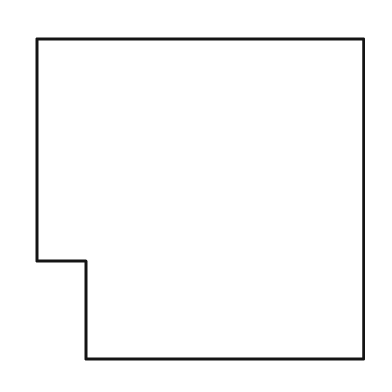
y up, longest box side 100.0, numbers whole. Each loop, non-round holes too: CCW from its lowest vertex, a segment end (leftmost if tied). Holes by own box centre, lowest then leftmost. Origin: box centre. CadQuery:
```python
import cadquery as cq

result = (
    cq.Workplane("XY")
    .moveTo(-35.0, -49.0)
    .lineTo(50.0, -49.0)
    .lineTo(50.0, 49.0)
    .lineTo(-50.0, 49.0)
    .lineTo(-50.0, -19.0)
    .lineTo(-35.0, -19.0)
    .close()
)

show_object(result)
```